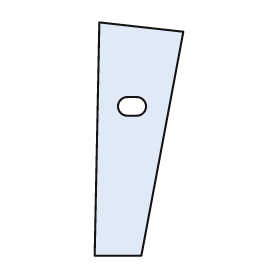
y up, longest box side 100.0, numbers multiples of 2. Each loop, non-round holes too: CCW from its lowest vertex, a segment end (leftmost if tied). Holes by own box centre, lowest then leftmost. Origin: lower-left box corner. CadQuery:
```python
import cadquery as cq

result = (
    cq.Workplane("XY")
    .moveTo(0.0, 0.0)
    .lineTo(20.0, 0.0)
    .lineTo(38.0, 96.0)
    .lineTo(2.0, 100.0)
    .close()
    .moveTo(14.0, 60.0)
    .lineTo(18.0, 60.0)
    .threePointArc((22.0, 64.0), (18.0, 68.0))
    .lineTo(14.0, 68.0)
    .threePointArc((10.0, 64.0), (14.0, 60.0))
    .close()
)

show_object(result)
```